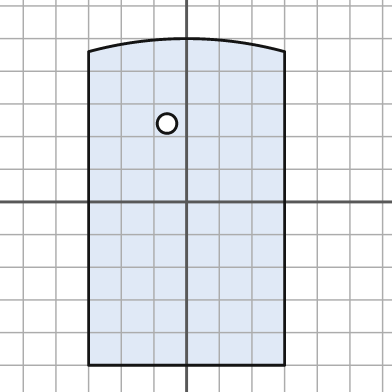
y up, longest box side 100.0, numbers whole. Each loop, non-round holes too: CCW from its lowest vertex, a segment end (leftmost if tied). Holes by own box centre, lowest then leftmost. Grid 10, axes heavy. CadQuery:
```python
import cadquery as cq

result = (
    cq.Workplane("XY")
    .moveTo(-30.0, -50.0)
    .lineTo(30.0, -50.0)
    .lineTo(30.0, 46.0)
    .threePointArc((0.0, 50.0), (-30.0, 46.0))
    .close()
    .moveTo(-6.0, 24.0)
    .circle(3.0)
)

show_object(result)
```